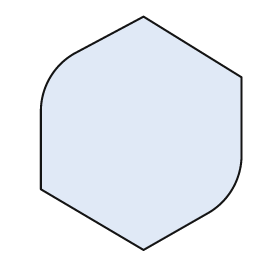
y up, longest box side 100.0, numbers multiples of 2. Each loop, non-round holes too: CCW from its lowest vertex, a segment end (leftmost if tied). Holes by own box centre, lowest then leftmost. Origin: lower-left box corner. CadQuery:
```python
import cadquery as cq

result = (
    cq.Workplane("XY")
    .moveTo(44.0, 0.0)
    .lineTo(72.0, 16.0)
    .threePointArc((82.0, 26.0), (86.0, 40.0))
    .lineTo(86.0, 74.0)
    .lineTo(44.0, 100.0)
    .lineTo(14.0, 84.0)
    .threePointArc((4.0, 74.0), (0.0, 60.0))
    .lineTo(0.0, 26.0)
    .close()
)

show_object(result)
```